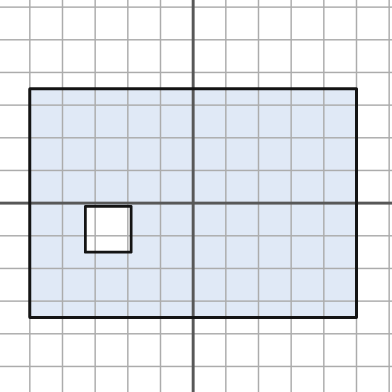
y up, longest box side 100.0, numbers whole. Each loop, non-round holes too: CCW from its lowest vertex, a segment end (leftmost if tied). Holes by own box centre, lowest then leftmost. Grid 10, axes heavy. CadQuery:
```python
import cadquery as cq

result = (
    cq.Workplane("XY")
    .moveTo(-50.0, -35.0)
    .lineTo(50.0, -35.0)
    .lineTo(50.0, 35.0)
    .lineTo(-50.0, 35.0)
    .close()
    .moveTo(-33.0, -15.0)
    .lineTo(-19.0, -15.0)
    .lineTo(-19.0, -1.0)
    .lineTo(-33.0, -1.0)
    .close()
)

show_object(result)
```